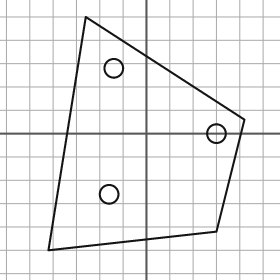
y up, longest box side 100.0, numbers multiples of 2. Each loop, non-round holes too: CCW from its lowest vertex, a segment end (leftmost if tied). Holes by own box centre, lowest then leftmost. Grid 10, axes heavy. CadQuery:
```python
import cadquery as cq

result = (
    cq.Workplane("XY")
    .moveTo(-42.0, -50.0)
    .lineTo(30.0, -42.0)
    .lineTo(42.0, 6.0)
    .lineTo(-26.0, 50.0)
    .close()
    .moveTo(-16.0, -26.0)
    .circle(4.0)
    .moveTo(30.0, 0.0)
    .circle(4.0)
    .moveTo(-14.0, 28.0)
    .circle(4.0)
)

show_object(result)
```